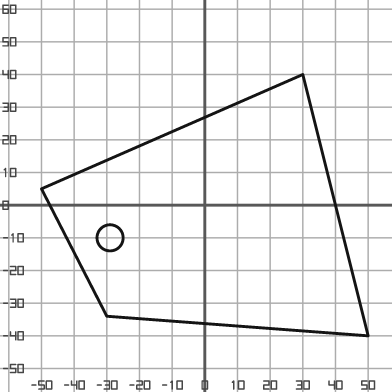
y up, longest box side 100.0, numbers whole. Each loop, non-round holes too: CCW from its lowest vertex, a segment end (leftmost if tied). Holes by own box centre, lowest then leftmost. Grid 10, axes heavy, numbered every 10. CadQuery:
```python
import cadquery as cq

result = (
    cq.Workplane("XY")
    .moveTo(50.0, -40.0)
    .lineTo(30.0, 40.0)
    .lineTo(-50.0, 5.0)
    .lineTo(-30.0, -34.0)
    .close()
    .moveTo(-29.0, -10.0)
    .circle(4.0)
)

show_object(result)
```